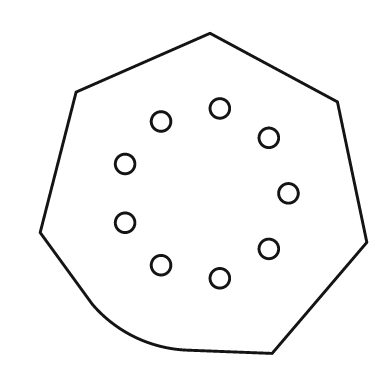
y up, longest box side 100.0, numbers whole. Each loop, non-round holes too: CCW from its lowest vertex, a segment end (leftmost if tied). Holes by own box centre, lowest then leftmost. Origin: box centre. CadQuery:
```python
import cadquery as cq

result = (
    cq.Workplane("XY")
    .moveTo(21.0, -49.0)
    .lineTo(50.0, -15.0)
    .lineTo(41.0, 28.0)
    .lineTo(2.0, 49.0)
    .lineTo(-39.0, 31.0)
    .lineTo(-50.0, -12.0)
    .lineTo(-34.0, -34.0)
    .threePointArc((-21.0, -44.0), (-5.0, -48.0))
    .close()
    .moveTo(5.0, -26.0)
    .circle(3.0)
    .moveTo(-13.0, -22.0)
    .circle(3.0)
    .moveTo(20.0, -17.0)
    .circle(3.0)
    .moveTo(-24.0, -9.0)
    .circle(3.0)
    .moveTo(26.0, 0.0)
    .circle(3.0)
    .moveTo(-24.0, 9.0)
    .circle(3.0)
    .moveTo(20.0, 17.0)
    .circle(3.0)
    .moveTo(-13.0, 22.0)
    .circle(3.0)
    .moveTo(5.0, 26.0)
    .circle(3.0)
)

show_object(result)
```